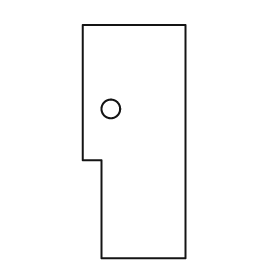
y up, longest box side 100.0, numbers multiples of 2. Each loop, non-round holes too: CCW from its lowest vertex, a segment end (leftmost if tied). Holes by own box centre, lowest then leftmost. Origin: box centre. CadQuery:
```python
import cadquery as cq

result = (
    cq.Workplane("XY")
    .moveTo(-14.0, -50.0)
    .lineTo(22.0, -50.0)
    .lineTo(22.0, 50.0)
    .lineTo(-22.0, 50.0)
    .lineTo(-22.0, -8.0)
    .lineTo(-14.0, -8.0)
    .close()
    .moveTo(-10.0, 14.0)
    .circle(4.0)
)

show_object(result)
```